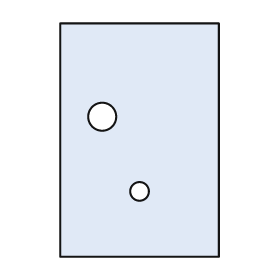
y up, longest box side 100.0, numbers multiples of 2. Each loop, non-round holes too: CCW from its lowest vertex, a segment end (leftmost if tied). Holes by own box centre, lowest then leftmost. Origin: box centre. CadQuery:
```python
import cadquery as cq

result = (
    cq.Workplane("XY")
    .moveTo(-34.0, -50.0)
    .lineTo(34.0, -50.0)
    .lineTo(34.0, 50.0)
    .lineTo(-34.0, 50.0)
    .close()
    .moveTo(0.0, -22.0)
    .circle(4.0)
    .moveTo(-16.0, 10.0)
    .circle(6.0)
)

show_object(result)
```